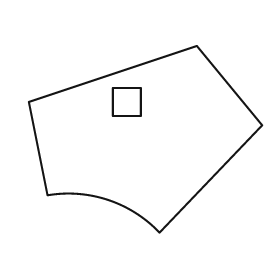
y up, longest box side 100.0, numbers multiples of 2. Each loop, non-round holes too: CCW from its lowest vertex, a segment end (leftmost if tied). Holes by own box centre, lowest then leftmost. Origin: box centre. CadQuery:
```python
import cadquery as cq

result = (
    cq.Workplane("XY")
    .moveTo(6.0, -40.0)
    .lineTo(50.0, 6.0)
    .lineTo(22.0, 40.0)
    .lineTo(-50.0, 16.0)
    .lineTo(-42.0, -24.0)
    .threePointArc((-16.0, -26.0), (6.0, -40.0))
    .close()
    .moveTo(-14.0, 10.0)
    .lineTo(-2.0, 10.0)
    .lineTo(-2.0, 22.0)
    .lineTo(-14.0, 22.0)
    .close()
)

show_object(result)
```